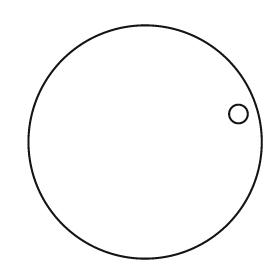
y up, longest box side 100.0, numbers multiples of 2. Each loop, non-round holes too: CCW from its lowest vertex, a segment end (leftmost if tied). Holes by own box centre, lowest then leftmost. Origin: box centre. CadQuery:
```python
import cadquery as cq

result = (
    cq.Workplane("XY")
    .moveTo(0.0, 0.0)
    .circle(50.0)
    .moveTo(40.0, 12.0)
    .circle(4.0)
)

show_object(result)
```